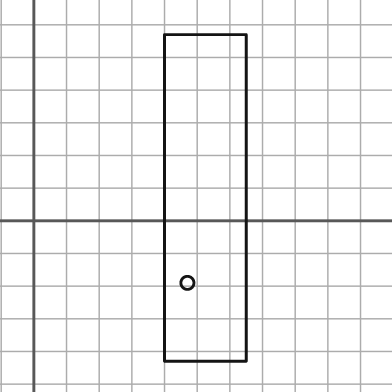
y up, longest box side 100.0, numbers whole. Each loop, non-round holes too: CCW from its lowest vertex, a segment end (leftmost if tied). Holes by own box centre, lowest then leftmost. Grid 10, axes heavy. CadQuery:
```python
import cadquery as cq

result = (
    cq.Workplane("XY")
    .moveTo(40.0, -43.0)
    .lineTo(65.0, -43.0)
    .lineTo(65.0, 57.0)
    .lineTo(40.0, 57.0)
    .close()
    .moveTo(47.0, -19.0)
    .circle(2.0)
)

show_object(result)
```